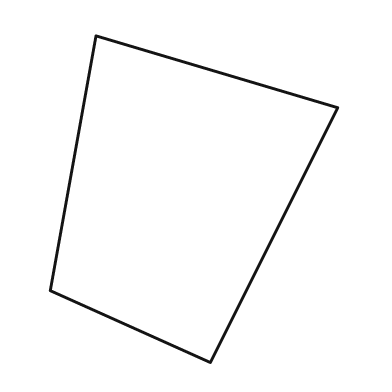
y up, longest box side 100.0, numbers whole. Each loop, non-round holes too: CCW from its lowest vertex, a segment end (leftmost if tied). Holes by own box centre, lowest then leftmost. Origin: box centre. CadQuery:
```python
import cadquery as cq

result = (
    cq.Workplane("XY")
    .moveTo(5.0, -50.0)
    .lineTo(44.0, 28.0)
    .lineTo(-30.0, 50.0)
    .lineTo(-44.0, -28.0)
    .close()
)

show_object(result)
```